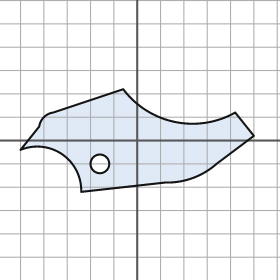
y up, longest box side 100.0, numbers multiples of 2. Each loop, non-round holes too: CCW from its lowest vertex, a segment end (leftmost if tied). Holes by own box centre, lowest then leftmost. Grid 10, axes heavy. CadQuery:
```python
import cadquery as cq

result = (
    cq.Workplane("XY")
    .moveTo(-24.0, -22.0)
    .lineTo(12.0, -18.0)
    .threePointArc((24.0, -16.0), (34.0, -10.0))
    .lineTo(50.0, 2.0)
    .lineTo(42.0, 12.0)
    .threePointArc((16.0, 8.0), (-6.0, 22.0))
    .lineTo(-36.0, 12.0)
    .threePointArc((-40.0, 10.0), (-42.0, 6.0))
    .lineTo(-50.0, -4.0)
    .threePointArc((-32.0, -6.0), (-24.0, -22.0))
    .close()
    .moveTo(-16.0, -10.0)
    .circle(4.0)
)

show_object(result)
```